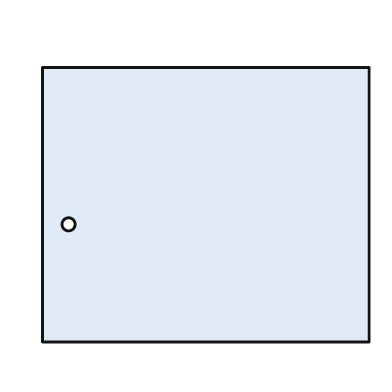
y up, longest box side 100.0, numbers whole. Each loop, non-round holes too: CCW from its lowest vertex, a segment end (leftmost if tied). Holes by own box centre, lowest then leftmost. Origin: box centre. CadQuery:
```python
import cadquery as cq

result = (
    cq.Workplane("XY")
    .moveTo(-50.0, -42.0)
    .lineTo(50.0, -42.0)
    .lineTo(50.0, 42.0)
    .lineTo(-50.0, 42.0)
    .close()
    .moveTo(-42.0, -6.0)
    .circle(2.0)
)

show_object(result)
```